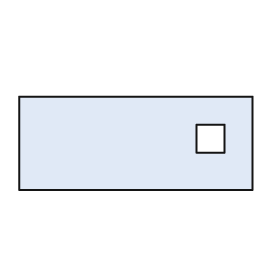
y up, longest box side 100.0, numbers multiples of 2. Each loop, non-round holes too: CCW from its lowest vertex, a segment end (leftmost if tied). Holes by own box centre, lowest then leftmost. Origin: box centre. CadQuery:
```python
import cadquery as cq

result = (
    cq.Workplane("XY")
    .moveTo(-50.0, -20.0)
    .lineTo(50.0, -20.0)
    .lineTo(50.0, 20.0)
    .lineTo(-50.0, 20.0)
    .close()
    .moveTo(26.0, -4.0)
    .lineTo(38.0, -4.0)
    .lineTo(38.0, 8.0)
    .lineTo(26.0, 8.0)
    .close()
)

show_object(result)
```